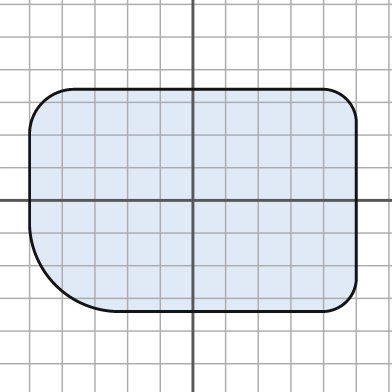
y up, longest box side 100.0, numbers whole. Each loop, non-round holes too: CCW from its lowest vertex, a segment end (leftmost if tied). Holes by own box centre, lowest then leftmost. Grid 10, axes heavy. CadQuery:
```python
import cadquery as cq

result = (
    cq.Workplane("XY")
    .moveTo(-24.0, -34.0)
    .lineTo(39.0, -34.0)
    .threePointArc((47.0, -31.0), (50.0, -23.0))
    .lineTo(50.0, 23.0)
    .threePointArc((47.0, 31.0), (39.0, 34.0))
    .lineTo(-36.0, 34.0)
    .threePointArc((-46.0, 30.0), (-50.0, 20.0))
    .lineTo(-50.0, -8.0)
    .threePointArc((-42.0, -26.0), (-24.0, -34.0))
    .close()
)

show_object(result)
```